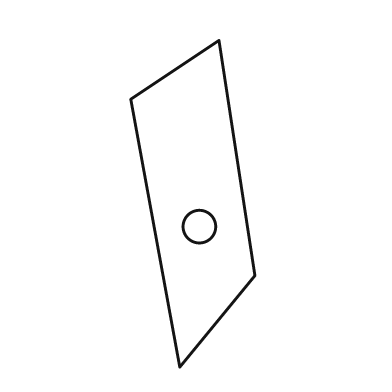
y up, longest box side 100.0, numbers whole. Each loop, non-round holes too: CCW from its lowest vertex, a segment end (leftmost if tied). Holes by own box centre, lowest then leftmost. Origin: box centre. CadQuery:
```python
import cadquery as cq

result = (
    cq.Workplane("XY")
    .moveTo(-4.0, -50.0)
    .lineTo(19.0, -22.0)
    .lineTo(8.0, 50.0)
    .lineTo(-19.0, 32.0)
    .close()
    .moveTo(2.0, -7.0)
    .circle(5.0)
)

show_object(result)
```